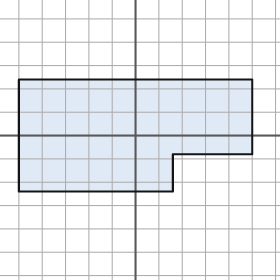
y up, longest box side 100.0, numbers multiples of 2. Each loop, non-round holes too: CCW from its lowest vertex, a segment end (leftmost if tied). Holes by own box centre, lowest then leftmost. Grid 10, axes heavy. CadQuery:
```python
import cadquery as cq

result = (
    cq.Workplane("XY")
    .moveTo(-50.0, -24.0)
    .lineTo(16.0, -24.0)
    .lineTo(16.0, -8.0)
    .lineTo(50.0, -8.0)
    .lineTo(50.0, 24.0)
    .lineTo(-50.0, 24.0)
    .close()
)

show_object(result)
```